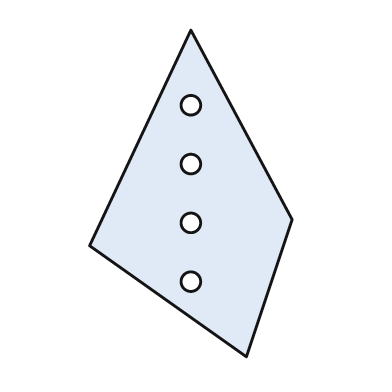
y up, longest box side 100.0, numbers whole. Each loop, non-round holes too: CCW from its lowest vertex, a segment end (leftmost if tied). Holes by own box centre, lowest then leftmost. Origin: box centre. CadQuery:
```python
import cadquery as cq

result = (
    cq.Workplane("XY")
    .moveTo(17.0, -50.0)
    .lineTo(31.0, -8.0)
    .lineTo(0.0, 50.0)
    .lineTo(-31.0, -16.0)
    .close()
    .moveTo(0.0, -27.0)
    .circle(3.0)
    .moveTo(0.0, -9.0)
    .circle(3.0)
    .moveTo(0.0, 9.0)
    .circle(3.0)
    .moveTo(0.0, 27.0)
    .circle(3.0)
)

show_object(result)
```